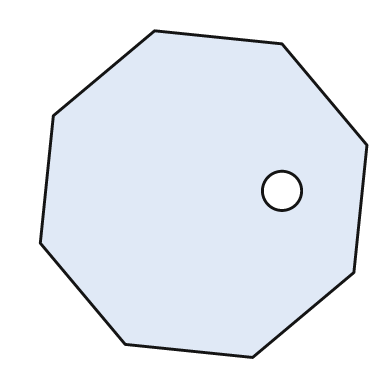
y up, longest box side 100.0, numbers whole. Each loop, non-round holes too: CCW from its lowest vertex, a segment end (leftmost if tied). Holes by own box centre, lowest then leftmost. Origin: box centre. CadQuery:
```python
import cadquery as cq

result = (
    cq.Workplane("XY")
    .moveTo(15.0, -50.0)
    .lineTo(46.0, -24.0)
    .lineTo(50.0, 15.0)
    .lineTo(24.0, 46.0)
    .lineTo(-15.0, 50.0)
    .lineTo(-46.0, 24.0)
    .lineTo(-50.0, -15.0)
    .lineTo(-24.0, -46.0)
    .close()
    .moveTo(24.0, 1.0)
    .circle(6.0)
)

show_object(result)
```